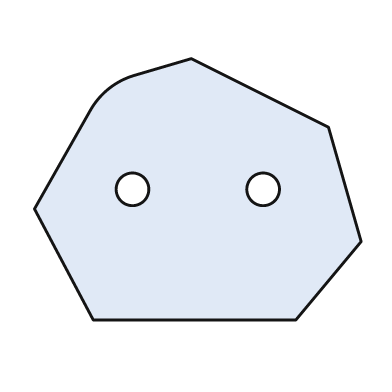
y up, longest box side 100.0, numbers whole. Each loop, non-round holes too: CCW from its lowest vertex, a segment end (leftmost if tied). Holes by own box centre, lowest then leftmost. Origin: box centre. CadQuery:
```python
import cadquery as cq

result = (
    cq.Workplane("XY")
    .moveTo(-32.0, -40.0)
    .lineTo(30.0, -40.0)
    .lineTo(50.0, -16.0)
    .lineTo(40.0, 19.0)
    .lineTo(-2.0, 40.0)
    .lineTo(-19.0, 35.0)
    .threePointArc((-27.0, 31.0), (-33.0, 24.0))
    .lineTo(-50.0, -6.0)
    .close()
    .moveTo(-20.0, 0.0)
    .circle(5.0)
    .moveTo(20.0, 0.0)
    .circle(5.0)
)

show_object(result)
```